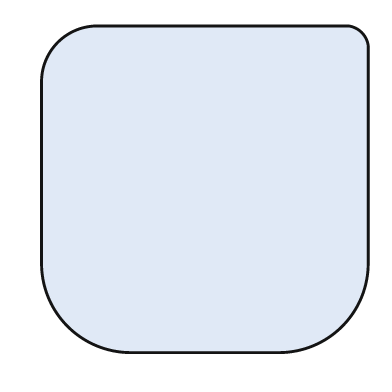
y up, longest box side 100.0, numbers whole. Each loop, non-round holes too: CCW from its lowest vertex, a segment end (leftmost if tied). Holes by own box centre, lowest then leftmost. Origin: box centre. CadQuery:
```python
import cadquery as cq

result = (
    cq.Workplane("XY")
    .moveTo(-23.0, -50.0)
    .lineTo(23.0, -50.0)
    .threePointArc((42.0, -42.0), (50.0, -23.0))
    .lineTo(50.0, 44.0)
    .threePointArc((48.0, 48.0), (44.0, 50.0))
    .lineTo(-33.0, 50.0)
    .threePointArc((-45.0, 45.0), (-50.0, 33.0))
    .lineTo(-50.0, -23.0)
    .threePointArc((-42.0, -42.0), (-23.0, -50.0))
    .close()
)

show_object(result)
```